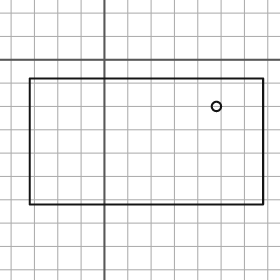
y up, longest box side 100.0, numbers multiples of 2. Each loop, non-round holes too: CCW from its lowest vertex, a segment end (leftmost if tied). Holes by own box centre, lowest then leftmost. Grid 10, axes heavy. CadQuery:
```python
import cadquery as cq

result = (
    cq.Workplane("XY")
    .moveTo(-32.0, -62.0)
    .lineTo(68.0, -62.0)
    .lineTo(68.0, -8.0)
    .lineTo(-32.0, -8.0)
    .close()
    .moveTo(48.0, -20.0)
    .circle(2.0)
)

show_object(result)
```